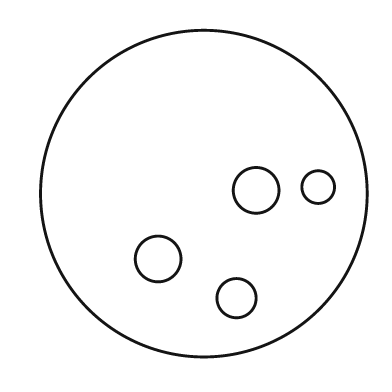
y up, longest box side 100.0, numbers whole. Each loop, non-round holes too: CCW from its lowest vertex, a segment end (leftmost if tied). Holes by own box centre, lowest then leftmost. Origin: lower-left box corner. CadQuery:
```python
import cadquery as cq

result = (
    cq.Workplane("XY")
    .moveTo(50.0, 50.0)
    .circle(50.0)
    .moveTo(60.0, 18.0)
    .circle(6.0)
    .moveTo(36.0, 30.0)
    .circle(7.0)
    .moveTo(66.0, 51.0)
    .circle(7.0)
    .moveTo(85.0, 52.0)
    .circle(5.0)
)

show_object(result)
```